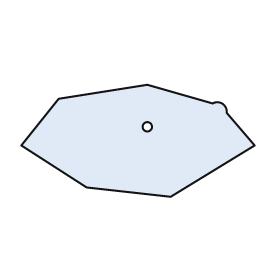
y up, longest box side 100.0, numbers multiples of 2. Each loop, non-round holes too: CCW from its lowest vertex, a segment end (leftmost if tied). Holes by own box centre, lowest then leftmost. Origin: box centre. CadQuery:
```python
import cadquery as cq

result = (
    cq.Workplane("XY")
    .moveTo(14.0, -24.0)
    .lineTo(50.0, -2.0)
    .lineTo(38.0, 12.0)
    .threePointArc((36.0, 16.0), (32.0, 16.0))
    .lineTo(4.0, 24.0)
    .lineTo(-34.0, 18.0)
    .lineTo(-50.0, -2.0)
    .lineTo(-22.0, -20.0)
    .close()
    .moveTo(4.0, 6.0)
    .circle(2.0)
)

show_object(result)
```